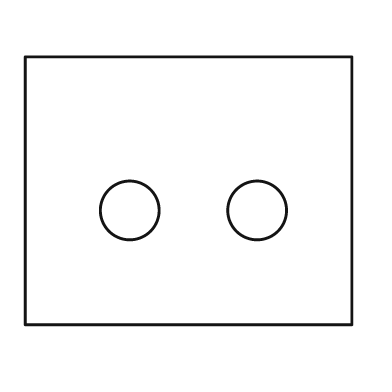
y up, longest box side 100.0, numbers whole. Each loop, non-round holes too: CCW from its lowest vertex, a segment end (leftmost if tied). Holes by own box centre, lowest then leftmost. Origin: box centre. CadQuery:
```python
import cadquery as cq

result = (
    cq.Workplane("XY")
    .moveTo(-50.0, -41.0)
    .lineTo(50.0, -41.0)
    .lineTo(50.0, 41.0)
    .lineTo(-50.0, 41.0)
    .close()
    .moveTo(-18.0, -6.0)
    .circle(9.0)
    .moveTo(21.0, -6.0)
    .circle(9.0)
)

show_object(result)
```